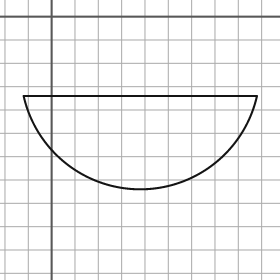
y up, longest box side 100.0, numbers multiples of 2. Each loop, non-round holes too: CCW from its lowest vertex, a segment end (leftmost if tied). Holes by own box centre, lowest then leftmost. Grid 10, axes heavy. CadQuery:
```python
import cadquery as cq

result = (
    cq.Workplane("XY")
    .moveTo(-12.0, -34.0)
    .threePointArc((38.0, -74.0), (88.0, -34.0))
    .close()
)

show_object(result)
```